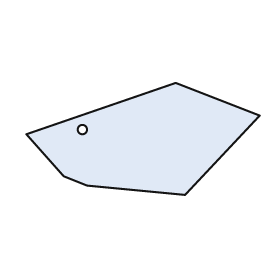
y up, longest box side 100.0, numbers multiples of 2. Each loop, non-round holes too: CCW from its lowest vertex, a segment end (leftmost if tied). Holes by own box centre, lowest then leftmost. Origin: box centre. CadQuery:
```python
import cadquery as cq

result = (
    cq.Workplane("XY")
    .moveTo(18.0, -24.0)
    .lineTo(50.0, 10.0)
    .lineTo(14.0, 24.0)
    .lineTo(-50.0, 2.0)
    .lineTo(-34.0, -16.0)
    .lineTo(-24.0, -20.0)
    .close()
    .moveTo(-26.0, 4.0)
    .circle(2.0)
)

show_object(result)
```